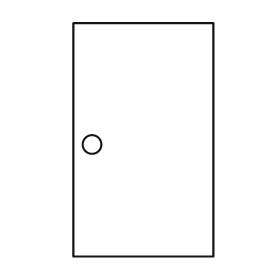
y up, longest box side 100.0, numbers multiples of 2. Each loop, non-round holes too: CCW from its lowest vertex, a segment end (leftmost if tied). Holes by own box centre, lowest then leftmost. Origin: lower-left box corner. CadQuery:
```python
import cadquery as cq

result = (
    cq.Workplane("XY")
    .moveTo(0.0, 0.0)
    .lineTo(60.0, 0.0)
    .lineTo(60.0, 100.0)
    .lineTo(0.0, 100.0)
    .close()
    .moveTo(8.0, 48.0)
    .circle(4.0)
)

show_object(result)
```